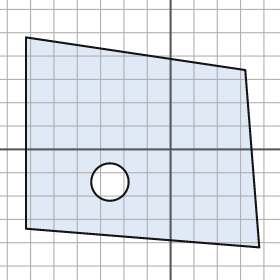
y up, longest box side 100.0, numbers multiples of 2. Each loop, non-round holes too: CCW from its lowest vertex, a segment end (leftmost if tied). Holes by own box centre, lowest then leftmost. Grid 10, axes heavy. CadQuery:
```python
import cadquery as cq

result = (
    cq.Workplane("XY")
    .moveTo(38.0, -42.0)
    .lineTo(32.0, 34.0)
    .lineTo(-62.0, 48.0)
    .lineTo(-62.0, -34.0)
    .close()
    .moveTo(-26.0, -14.0)
    .circle(8.0)
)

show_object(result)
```